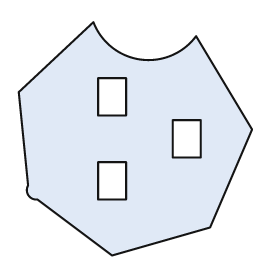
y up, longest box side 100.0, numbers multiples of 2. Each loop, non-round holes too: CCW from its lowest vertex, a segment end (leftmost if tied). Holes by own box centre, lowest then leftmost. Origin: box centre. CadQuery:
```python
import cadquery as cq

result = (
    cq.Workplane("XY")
    .moveTo(-10.0, -50.0)
    .lineTo(32.0, -38.0)
    .lineTo(50.0, 4.0)
    .lineTo(26.0, 44.0)
    .threePointArc((2.0, 34.0), (-18.0, 50.0))
    .lineTo(-50.0, 20.0)
    .lineTo(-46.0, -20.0)
    .threePointArc((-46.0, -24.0), (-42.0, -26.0))
    .close()
    .moveTo(-16.0, -26.0)
    .lineTo(-4.0, -26.0)
    .lineTo(-4.0, -10.0)
    .lineTo(-16.0, -10.0)
    .close()
    .moveTo(16.0, -8.0)
    .lineTo(28.0, -8.0)
    .lineTo(28.0, 8.0)
    .lineTo(16.0, 8.0)
    .close()
    .moveTo(-16.0, 10.0)
    .lineTo(-4.0, 10.0)
    .lineTo(-4.0, 26.0)
    .lineTo(-16.0, 26.0)
    .close()
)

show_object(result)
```